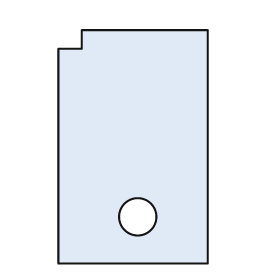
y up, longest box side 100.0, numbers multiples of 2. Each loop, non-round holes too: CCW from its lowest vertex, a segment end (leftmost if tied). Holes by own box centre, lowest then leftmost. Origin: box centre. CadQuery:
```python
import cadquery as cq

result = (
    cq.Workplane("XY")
    .moveTo(-32.0, -50.0)
    .lineTo(32.0, -50.0)
    .lineTo(32.0, 50.0)
    .lineTo(-22.0, 50.0)
    .lineTo(-22.0, 42.0)
    .lineTo(-32.0, 42.0)
    .close()
    .moveTo(2.0, -30.0)
    .circle(8.0)
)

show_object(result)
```